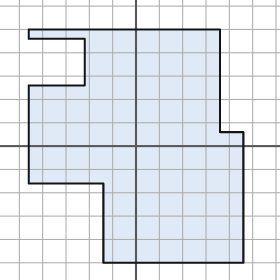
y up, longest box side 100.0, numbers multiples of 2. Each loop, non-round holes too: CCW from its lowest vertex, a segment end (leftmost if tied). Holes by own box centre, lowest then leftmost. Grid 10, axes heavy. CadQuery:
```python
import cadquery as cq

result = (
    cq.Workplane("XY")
    .moveTo(-14.0, -50.0)
    .lineTo(46.0, -50.0)
    .lineTo(46.0, 6.0)
    .lineTo(36.0, 6.0)
    .lineTo(36.0, 50.0)
    .lineTo(-46.0, 50.0)
    .lineTo(-46.0, 46.0)
    .lineTo(-22.0, 46.0)
    .lineTo(-22.0, 26.0)
    .lineTo(-46.0, 26.0)
    .lineTo(-46.0, -16.0)
    .lineTo(-14.0, -16.0)
    .close()
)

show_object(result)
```